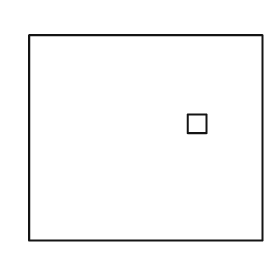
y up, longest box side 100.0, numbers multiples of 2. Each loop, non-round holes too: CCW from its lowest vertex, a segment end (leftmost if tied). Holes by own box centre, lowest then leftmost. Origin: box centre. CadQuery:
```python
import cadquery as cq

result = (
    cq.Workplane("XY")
    .moveTo(-50.0, -44.0)
    .lineTo(50.0, -44.0)
    .lineTo(50.0, 44.0)
    .lineTo(-50.0, 44.0)
    .close()
    .moveTo(18.0, 2.0)
    .lineTo(26.0, 2.0)
    .lineTo(26.0, 10.0)
    .lineTo(18.0, 10.0)
    .close()
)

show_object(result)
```